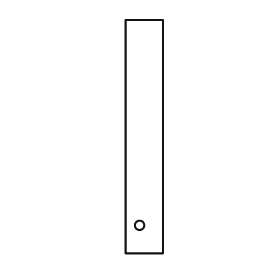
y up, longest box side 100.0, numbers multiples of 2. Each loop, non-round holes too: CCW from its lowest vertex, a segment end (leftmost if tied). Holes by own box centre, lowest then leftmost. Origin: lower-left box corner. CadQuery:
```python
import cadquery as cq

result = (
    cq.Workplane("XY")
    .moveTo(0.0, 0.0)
    .lineTo(16.0, 0.0)
    .lineTo(16.0, 100.0)
    .lineTo(0.0, 100.0)
    .close()
    .moveTo(6.0, 12.0)
    .circle(2.0)
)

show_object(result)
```